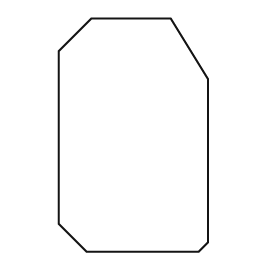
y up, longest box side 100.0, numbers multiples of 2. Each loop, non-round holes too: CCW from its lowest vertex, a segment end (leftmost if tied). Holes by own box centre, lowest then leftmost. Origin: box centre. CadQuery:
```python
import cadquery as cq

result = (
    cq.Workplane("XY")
    .moveTo(-20.0, -50.0)
    .lineTo(28.0, -50.0)
    .lineTo(32.0, -46.0)
    .lineTo(32.0, 24.0)
    .lineTo(16.0, 50.0)
    .lineTo(-18.0, 50.0)
    .lineTo(-32.0, 36.0)
    .lineTo(-32.0, -38.0)
    .close()
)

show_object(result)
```